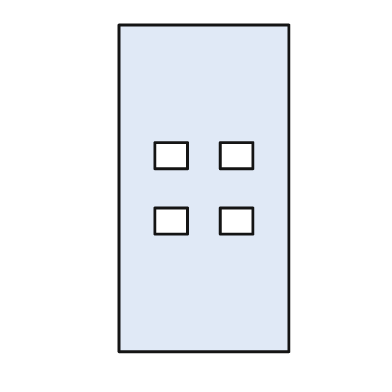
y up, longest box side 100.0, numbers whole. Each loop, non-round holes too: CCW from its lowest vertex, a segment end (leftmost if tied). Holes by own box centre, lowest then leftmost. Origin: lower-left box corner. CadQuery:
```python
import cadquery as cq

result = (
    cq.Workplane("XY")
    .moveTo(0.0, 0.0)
    .lineTo(52.0, 0.0)
    .lineTo(52.0, 100.0)
    .lineTo(0.0, 100.0)
    .close()
    .moveTo(11.0, 36.0)
    .lineTo(21.0, 36.0)
    .lineTo(21.0, 44.0)
    .lineTo(11.0, 44.0)
    .close()
    .moveTo(31.0, 36.0)
    .lineTo(41.0, 36.0)
    .lineTo(41.0, 44.0)
    .lineTo(31.0, 44.0)
    .close()
    .moveTo(11.0, 56.0)
    .lineTo(21.0, 56.0)
    .lineTo(21.0, 64.0)
    .lineTo(11.0, 64.0)
    .close()
    .moveTo(31.0, 56.0)
    .lineTo(41.0, 56.0)
    .lineTo(41.0, 64.0)
    .lineTo(31.0, 64.0)
    .close()
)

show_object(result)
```